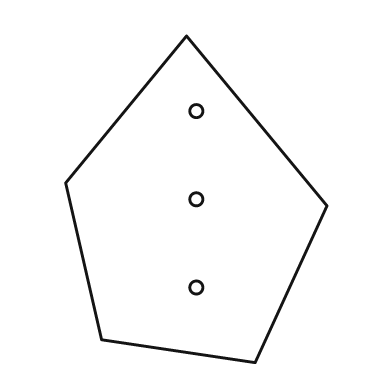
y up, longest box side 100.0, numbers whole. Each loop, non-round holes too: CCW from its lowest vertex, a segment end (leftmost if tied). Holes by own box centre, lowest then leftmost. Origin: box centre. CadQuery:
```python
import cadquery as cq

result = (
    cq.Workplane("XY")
    .moveTo(18.0, -50.0)
    .lineTo(40.0, -2.0)
    .lineTo(-3.0, 50.0)
    .lineTo(-40.0, 5.0)
    .lineTo(-29.0, -43.0)
    .close()
    .moveTo(0.0, -27.0)
    .circle(2.0)
    .moveTo(0.0, 0.0)
    .circle(2.0)
    .moveTo(0.0, 27.0)
    .circle(2.0)
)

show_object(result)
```